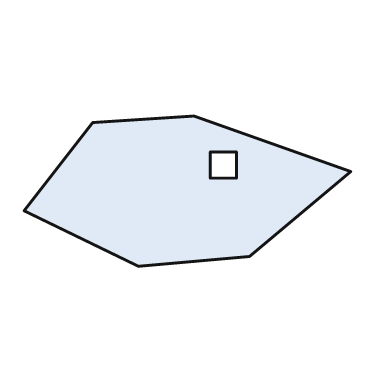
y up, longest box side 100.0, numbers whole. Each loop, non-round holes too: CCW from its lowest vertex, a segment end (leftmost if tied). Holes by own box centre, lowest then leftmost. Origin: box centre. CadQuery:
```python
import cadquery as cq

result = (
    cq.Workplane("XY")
    .moveTo(-15.0, -23.0)
    .lineTo(19.0, -20.0)
    .lineTo(50.0, 6.0)
    .lineTo(2.0, 23.0)
    .lineTo(-29.0, 21.0)
    .lineTo(-50.0, -6.0)
    .close()
    .moveTo(7.0, 4.0)
    .lineTo(15.0, 4.0)
    .lineTo(15.0, 12.0)
    .lineTo(7.0, 12.0)
    .close()
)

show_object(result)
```